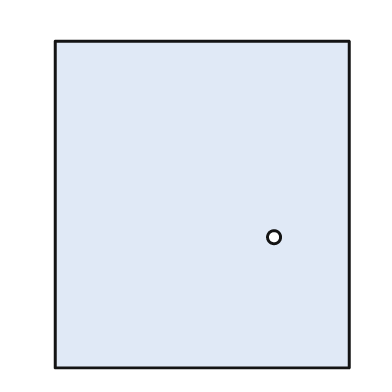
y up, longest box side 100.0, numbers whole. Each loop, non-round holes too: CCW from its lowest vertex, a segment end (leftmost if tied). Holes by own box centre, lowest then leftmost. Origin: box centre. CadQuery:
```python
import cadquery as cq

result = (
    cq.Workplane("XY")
    .moveTo(-45.0, -50.0)
    .lineTo(45.0, -50.0)
    .lineTo(45.0, 50.0)
    .lineTo(-45.0, 50.0)
    .close()
    .moveTo(22.0, -10.0)
    .circle(2.0)
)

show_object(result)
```